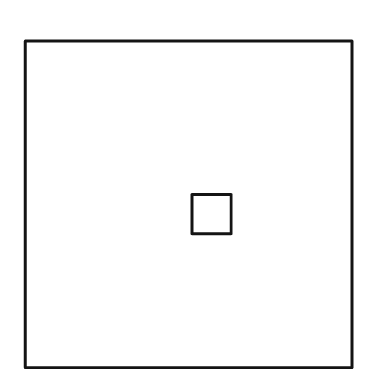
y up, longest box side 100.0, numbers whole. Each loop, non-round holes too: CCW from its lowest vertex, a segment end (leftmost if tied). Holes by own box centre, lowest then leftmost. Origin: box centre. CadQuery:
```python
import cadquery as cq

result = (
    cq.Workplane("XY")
    .moveTo(-50.0, -50.0)
    .lineTo(50.0, -50.0)
    .lineTo(50.0, 50.0)
    .lineTo(-50.0, 50.0)
    .close()
    .moveTo(1.0, -9.0)
    .lineTo(13.0, -9.0)
    .lineTo(13.0, 3.0)
    .lineTo(1.0, 3.0)
    .close()
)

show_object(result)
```